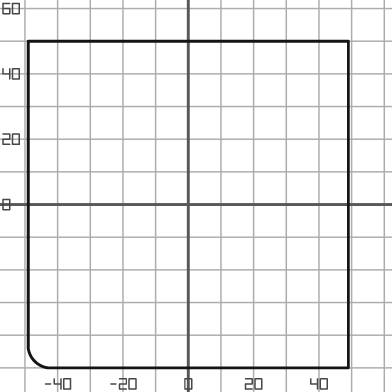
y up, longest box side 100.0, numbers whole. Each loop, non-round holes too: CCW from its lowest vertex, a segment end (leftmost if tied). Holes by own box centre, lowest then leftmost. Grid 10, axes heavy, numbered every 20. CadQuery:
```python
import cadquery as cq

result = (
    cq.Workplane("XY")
    .moveTo(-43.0, -50.0)
    .lineTo(49.0, -50.0)
    .lineTo(49.0, 50.0)
    .lineTo(-49.0, 50.0)
    .lineTo(-49.0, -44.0)
    .threePointArc((-47.0, -48.0), (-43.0, -50.0))
    .close()
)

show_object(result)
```